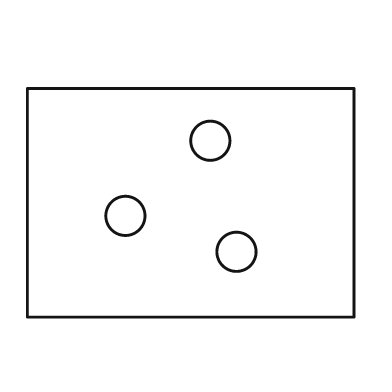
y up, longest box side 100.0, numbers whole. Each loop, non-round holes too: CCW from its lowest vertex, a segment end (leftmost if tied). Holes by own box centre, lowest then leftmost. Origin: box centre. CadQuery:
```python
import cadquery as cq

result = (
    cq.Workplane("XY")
    .moveTo(-50.0, -35.0)
    .lineTo(50.0, -35.0)
    .lineTo(50.0, 35.0)
    .lineTo(-50.0, 35.0)
    .close()
    .moveTo(14.0, -15.0)
    .circle(6.0)
    .moveTo(-20.0, -4.0)
    .circle(6.0)
    .moveTo(6.0, 19.0)
    .circle(6.0)
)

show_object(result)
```